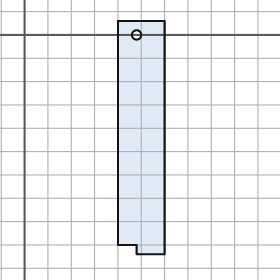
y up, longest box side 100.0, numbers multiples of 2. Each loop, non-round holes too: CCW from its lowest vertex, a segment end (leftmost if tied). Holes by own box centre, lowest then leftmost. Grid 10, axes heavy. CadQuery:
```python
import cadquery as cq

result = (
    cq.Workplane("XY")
    .moveTo(48.0, -94.0)
    .lineTo(60.0, -94.0)
    .lineTo(60.0, 6.0)
    .lineTo(40.0, 6.0)
    .lineTo(40.0, -90.0)
    .lineTo(48.0, -90.0)
    .close()
    .moveTo(48.0, 0.0)
    .circle(2.0)
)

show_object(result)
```